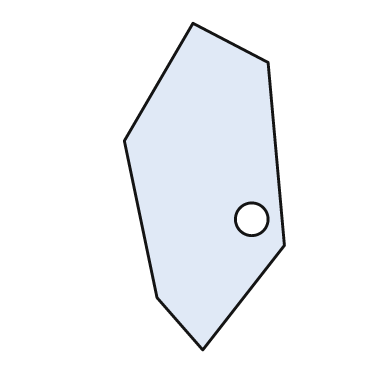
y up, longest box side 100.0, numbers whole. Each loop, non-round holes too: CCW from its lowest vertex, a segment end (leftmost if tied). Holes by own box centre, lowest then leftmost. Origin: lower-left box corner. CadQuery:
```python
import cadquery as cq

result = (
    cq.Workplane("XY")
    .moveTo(24.0, 0.0)
    .lineTo(49.0, 32.0)
    .lineTo(44.0, 88.0)
    .lineTo(21.0, 100.0)
    .lineTo(0.0, 64.0)
    .lineTo(10.0, 16.0)
    .close()
    .moveTo(39.0, 40.0)
    .circle(5.0)
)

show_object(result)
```